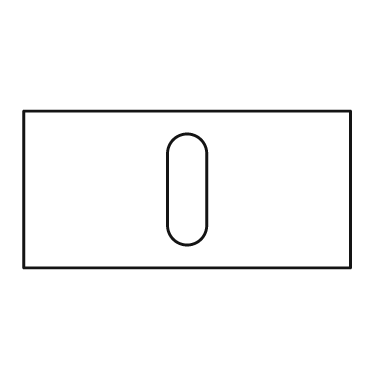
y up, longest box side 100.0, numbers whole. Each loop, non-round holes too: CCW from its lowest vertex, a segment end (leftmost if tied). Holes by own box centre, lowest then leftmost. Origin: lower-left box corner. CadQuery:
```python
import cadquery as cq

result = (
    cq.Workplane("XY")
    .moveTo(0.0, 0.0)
    .lineTo(100.0, 0.0)
    .lineTo(100.0, 48.0)
    .lineTo(0.0, 48.0)
    .close()
    .moveTo(44.0, 13.0)
    .threePointArc((50.0, 7.0), (56.0, 13.0))
    .lineTo(56.0, 35.0)
    .threePointArc((50.0, 41.0), (44.0, 35.0))
    .close()
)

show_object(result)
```